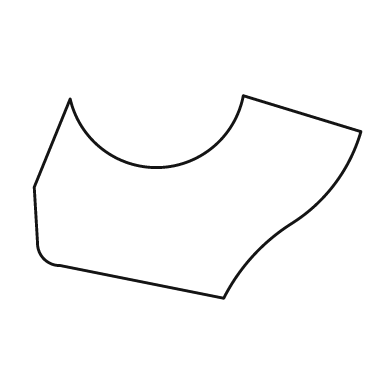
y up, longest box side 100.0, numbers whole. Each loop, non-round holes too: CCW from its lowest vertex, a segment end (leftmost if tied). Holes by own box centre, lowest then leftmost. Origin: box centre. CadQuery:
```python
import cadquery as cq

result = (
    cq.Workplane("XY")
    .moveTo(8.0, -31.0)
    .threePointArc((17.0, -18.0), (29.0, -8.0))
    .threePointArc((42.0, 4.0), (50.0, 20.0))
    .lineTo(14.0, 31.0)
    .threePointArc((-12.0, 9.0), (-39.0, 30.0))
    .lineTo(-50.0, 3.0)
    .lineTo(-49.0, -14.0)
    .threePointArc((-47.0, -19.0), (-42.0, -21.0))
    .close()
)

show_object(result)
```